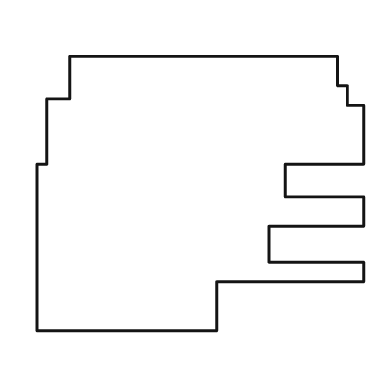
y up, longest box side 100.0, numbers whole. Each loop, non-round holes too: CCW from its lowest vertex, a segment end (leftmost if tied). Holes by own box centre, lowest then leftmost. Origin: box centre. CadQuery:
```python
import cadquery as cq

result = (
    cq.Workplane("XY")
    .moveTo(-50.0, -42.0)
    .lineTo(5.0, -42.0)
    .lineTo(5.0, -27.0)
    .lineTo(50.0, -27.0)
    .lineTo(50.0, -21.0)
    .lineTo(21.0, -21.0)
    .lineTo(21.0, -10.0)
    .lineTo(50.0, -10.0)
    .lineTo(50.0, -1.0)
    .lineTo(26.0, -1.0)
    .lineTo(26.0, 9.0)
    .lineTo(50.0, 9.0)
    .lineTo(50.0, 27.0)
    .lineTo(45.0, 27.0)
    .lineTo(45.0, 33.0)
    .lineTo(42.0, 33.0)
    .lineTo(42.0, 42.0)
    .lineTo(-40.0, 42.0)
    .lineTo(-40.0, 29.0)
    .lineTo(-47.0, 29.0)
    .lineTo(-47.0, 9.0)
    .lineTo(-50.0, 9.0)
    .close()
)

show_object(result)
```